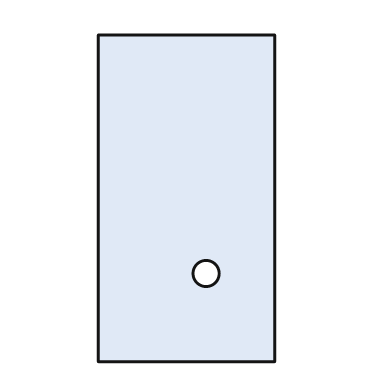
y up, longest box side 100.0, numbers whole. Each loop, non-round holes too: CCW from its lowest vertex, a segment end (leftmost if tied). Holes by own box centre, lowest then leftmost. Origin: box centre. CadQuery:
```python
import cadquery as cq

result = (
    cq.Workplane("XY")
    .moveTo(-27.0, -50.0)
    .lineTo(27.0, -50.0)
    .lineTo(27.0, 50.0)
    .lineTo(-27.0, 50.0)
    .close()
    .moveTo(6.0, -23.0)
    .circle(4.0)
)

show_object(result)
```